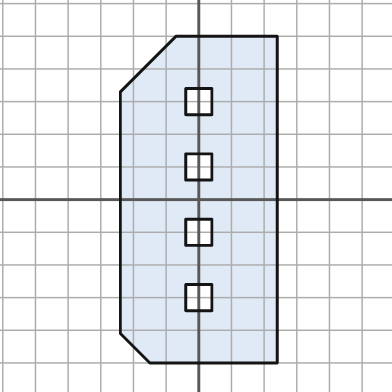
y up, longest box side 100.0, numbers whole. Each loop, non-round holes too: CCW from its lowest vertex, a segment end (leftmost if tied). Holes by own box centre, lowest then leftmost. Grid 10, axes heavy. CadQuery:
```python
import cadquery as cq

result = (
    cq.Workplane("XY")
    .moveTo(-15.0, -50.0)
    .lineTo(24.0, -50.0)
    .lineTo(24.0, 50.0)
    .lineTo(-7.0, 50.0)
    .lineTo(-24.0, 33.0)
    .lineTo(-24.0, -41.0)
    .close()
    .moveTo(-4.0, -34.0)
    .lineTo(4.0, -34.0)
    .lineTo(4.0, -26.0)
    .lineTo(-4.0, -26.0)
    .close()
    .moveTo(-4.0, -14.0)
    .lineTo(4.0, -14.0)
    .lineTo(4.0, -6.0)
    .lineTo(-4.0, -6.0)
    .close()
    .moveTo(-4.0, 6.0)
    .lineTo(4.0, 6.0)
    .lineTo(4.0, 14.0)
    .lineTo(-4.0, 14.0)
    .close()
    .moveTo(-4.0, 26.0)
    .lineTo(4.0, 26.0)
    .lineTo(4.0, 34.0)
    .lineTo(-4.0, 34.0)
    .close()
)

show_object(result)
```